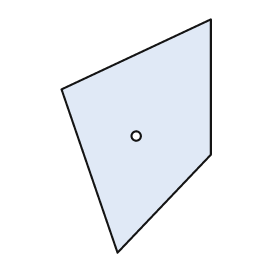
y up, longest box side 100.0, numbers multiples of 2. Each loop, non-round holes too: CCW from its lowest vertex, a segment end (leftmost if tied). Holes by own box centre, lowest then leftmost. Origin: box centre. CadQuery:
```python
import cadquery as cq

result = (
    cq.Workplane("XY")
    .moveTo(-8.0, -50.0)
    .lineTo(32.0, -8.0)
    .lineTo(32.0, 50.0)
    .lineTo(-32.0, 20.0)
    .close()
    .moveTo(0.0, 0.0)
    .circle(2.0)
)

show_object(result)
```